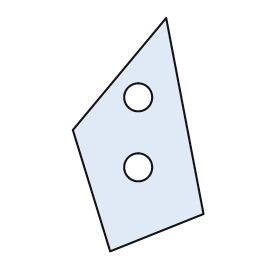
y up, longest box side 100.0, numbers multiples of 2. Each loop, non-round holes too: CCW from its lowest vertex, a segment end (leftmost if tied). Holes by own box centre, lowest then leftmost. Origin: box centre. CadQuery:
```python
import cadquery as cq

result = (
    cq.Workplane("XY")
    .moveTo(-12.0, -50.0)
    .lineTo(28.0, -34.0)
    .lineTo(12.0, 50.0)
    .lineTo(-28.0, 2.0)
    .close()
    .moveTo(0.0, -14.0)
    .circle(6.0)
    .moveTo(0.0, 16.0)
    .circle(6.0)
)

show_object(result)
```